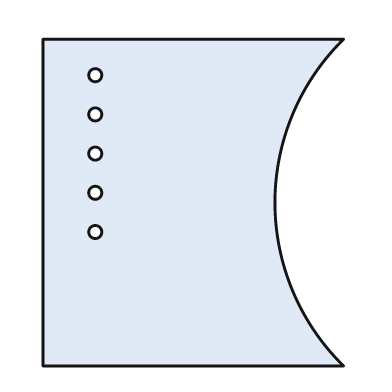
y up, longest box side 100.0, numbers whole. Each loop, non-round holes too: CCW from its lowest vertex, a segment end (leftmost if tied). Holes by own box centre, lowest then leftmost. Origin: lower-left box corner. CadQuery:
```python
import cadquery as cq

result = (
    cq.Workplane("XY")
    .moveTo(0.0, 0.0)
    .lineTo(92.0, 0.0)
    .threePointArc((71.0, 50.0), (92.0, 100.0))
    .lineTo(0.0, 100.0)
    .close()
    .moveTo(16.0, 41.0)
    .circle(2.0)
    .moveTo(16.0, 53.0)
    .circle(2.0)
    .moveTo(16.0, 65.0)
    .circle(2.0)
    .moveTo(16.0, 77.0)
    .circle(2.0)
    .moveTo(16.0, 89.0)
    .circle(2.0)
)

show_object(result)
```